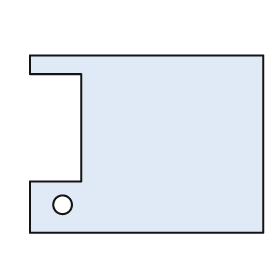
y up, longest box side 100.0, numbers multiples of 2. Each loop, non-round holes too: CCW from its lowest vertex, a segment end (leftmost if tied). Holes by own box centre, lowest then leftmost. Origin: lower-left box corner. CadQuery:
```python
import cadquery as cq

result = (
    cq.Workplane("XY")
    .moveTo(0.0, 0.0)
    .lineTo(100.0, 0.0)
    .lineTo(100.0, 76.0)
    .lineTo(0.0, 76.0)
    .lineTo(0.0, 68.0)
    .lineTo(22.0, 68.0)
    .lineTo(22.0, 22.0)
    .lineTo(0.0, 22.0)
    .close()
    .moveTo(14.0, 12.0)
    .circle(4.0)
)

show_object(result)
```